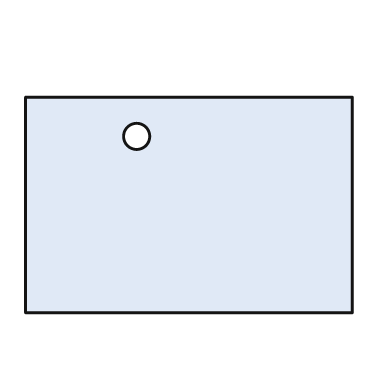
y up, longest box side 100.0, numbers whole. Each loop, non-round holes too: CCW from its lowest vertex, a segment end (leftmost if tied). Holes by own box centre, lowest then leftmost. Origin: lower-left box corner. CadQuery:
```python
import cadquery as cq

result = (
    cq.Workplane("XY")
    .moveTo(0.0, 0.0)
    .lineTo(100.0, 0.0)
    .lineTo(100.0, 66.0)
    .lineTo(0.0, 66.0)
    .close()
    .moveTo(34.0, 54.0)
    .circle(4.0)
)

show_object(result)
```